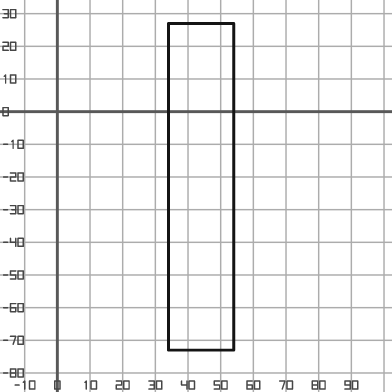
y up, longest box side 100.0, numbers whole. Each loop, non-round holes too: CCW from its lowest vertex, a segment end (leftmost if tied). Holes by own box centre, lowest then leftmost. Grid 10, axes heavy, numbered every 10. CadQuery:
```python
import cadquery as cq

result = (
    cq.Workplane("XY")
    .moveTo(34.0, -73.0)
    .lineTo(54.0, -73.0)
    .lineTo(54.0, 27.0)
    .lineTo(34.0, 27.0)
    .close()
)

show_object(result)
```